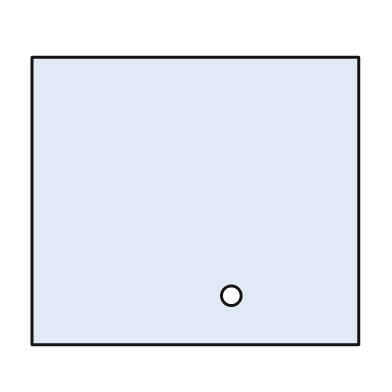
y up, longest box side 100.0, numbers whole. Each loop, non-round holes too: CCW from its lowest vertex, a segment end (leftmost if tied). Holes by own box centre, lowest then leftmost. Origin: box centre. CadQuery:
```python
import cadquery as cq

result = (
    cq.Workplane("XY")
    .moveTo(-50.0, -44.0)
    .lineTo(50.0, -44.0)
    .lineTo(50.0, 44.0)
    .lineTo(-50.0, 44.0)
    .close()
    .moveTo(11.0, -29.0)
    .circle(3.0)
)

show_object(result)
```